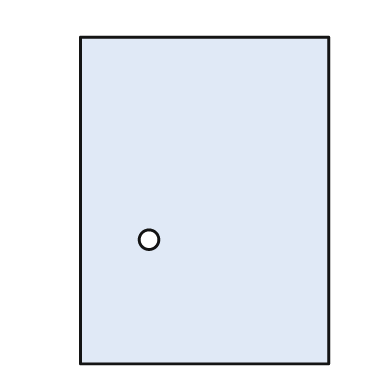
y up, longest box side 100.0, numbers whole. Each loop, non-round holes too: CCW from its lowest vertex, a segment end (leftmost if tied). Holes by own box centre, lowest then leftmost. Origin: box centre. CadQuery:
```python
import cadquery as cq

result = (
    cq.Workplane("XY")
    .moveTo(-38.0, -50.0)
    .lineTo(38.0, -50.0)
    .lineTo(38.0, 50.0)
    .lineTo(-38.0, 50.0)
    .close()
    .moveTo(-17.0, -12.0)
    .circle(3.0)
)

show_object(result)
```